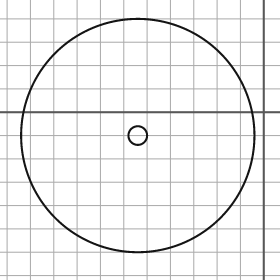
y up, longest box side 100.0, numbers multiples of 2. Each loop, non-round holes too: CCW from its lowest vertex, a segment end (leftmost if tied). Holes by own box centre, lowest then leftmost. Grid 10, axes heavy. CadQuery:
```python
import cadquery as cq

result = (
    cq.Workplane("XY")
    .moveTo(-54.0, -10.0)
    .circle(50.0)
    .moveTo(-54.0, -10.0)
    .circle(4.0)
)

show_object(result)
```